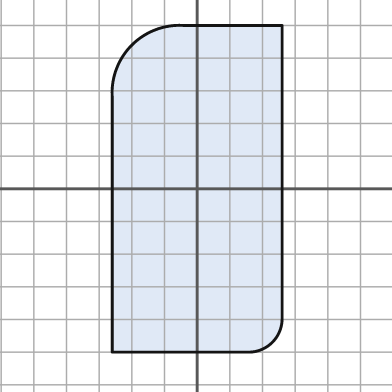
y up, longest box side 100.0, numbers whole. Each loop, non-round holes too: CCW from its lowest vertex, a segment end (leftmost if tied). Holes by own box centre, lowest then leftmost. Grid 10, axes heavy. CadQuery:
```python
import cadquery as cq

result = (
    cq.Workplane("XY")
    .moveTo(-26.0, -50.0)
    .lineTo(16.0, -50.0)
    .threePointArc((23.0, -47.0), (26.0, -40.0))
    .lineTo(26.0, 50.0)
    .lineTo(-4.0, 50.0)
    .threePointArc((-20.0, 44.0), (-26.0, 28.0))
    .close()
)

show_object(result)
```